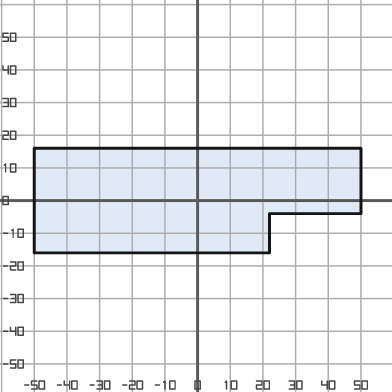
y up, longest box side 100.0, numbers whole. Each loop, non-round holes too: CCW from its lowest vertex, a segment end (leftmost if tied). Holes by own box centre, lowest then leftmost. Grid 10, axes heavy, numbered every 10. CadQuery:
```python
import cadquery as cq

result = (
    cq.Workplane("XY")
    .moveTo(-50.0, -16.0)
    .lineTo(22.0, -16.0)
    .lineTo(22.0, -4.0)
    .lineTo(50.0, -4.0)
    .lineTo(50.0, 16.0)
    .lineTo(-50.0, 16.0)
    .close()
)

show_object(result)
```